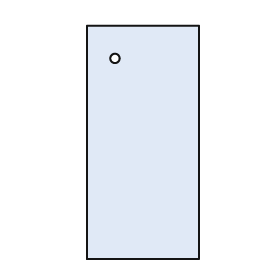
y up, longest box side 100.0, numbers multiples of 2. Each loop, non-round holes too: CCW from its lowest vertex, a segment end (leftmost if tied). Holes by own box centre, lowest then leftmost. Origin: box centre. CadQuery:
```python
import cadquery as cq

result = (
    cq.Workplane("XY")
    .moveTo(-24.0, -50.0)
    .lineTo(24.0, -50.0)
    .lineTo(24.0, 50.0)
    .lineTo(-24.0, 50.0)
    .close()
    .moveTo(-12.0, 36.0)
    .circle(2.0)
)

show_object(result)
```